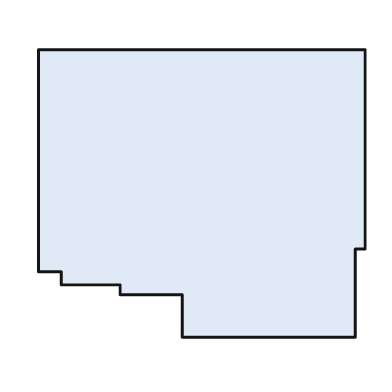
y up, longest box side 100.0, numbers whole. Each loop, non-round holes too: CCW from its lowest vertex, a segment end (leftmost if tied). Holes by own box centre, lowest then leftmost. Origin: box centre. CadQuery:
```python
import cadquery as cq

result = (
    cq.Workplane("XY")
    .moveTo(-6.0, -44.0)
    .lineTo(47.0, -44.0)
    .lineTo(47.0, -17.0)
    .lineTo(50.0, -17.0)
    .lineTo(50.0, 44.0)
    .lineTo(-50.0, 44.0)
    .lineTo(-50.0, -24.0)
    .lineTo(-43.0, -24.0)
    .lineTo(-43.0, -28.0)
    .lineTo(-25.0, -28.0)
    .lineTo(-25.0, -31.0)
    .lineTo(-6.0, -31.0)
    .close()
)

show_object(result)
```